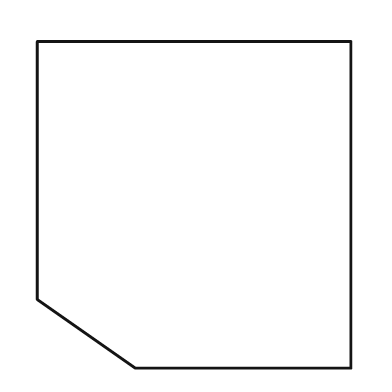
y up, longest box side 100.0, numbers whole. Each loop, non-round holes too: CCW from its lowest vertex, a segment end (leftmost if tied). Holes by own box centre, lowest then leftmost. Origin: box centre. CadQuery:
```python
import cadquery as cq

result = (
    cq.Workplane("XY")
    .moveTo(-18.0, -50.0)
    .lineTo(48.0, -50.0)
    .lineTo(48.0, 50.0)
    .lineTo(-48.0, 50.0)
    .lineTo(-48.0, -29.0)
    .close()
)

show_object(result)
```